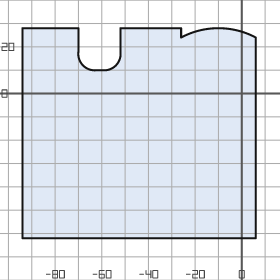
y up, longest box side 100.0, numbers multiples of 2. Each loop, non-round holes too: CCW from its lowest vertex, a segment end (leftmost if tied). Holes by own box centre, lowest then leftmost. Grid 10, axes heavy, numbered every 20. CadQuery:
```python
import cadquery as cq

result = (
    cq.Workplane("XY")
    .moveTo(-94.0, -62.0)
    .lineTo(6.0, -62.0)
    .lineTo(6.0, 24.0)
    .threePointArc((-10.0, 28.0), (-26.0, 24.0))
    .lineTo(-26.0, 28.0)
    .lineTo(-52.0, 28.0)
    .lineTo(-52.0, 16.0)
    .threePointArc((-54.0, 12.0), (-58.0, 10.0))
    .lineTo(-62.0, 10.0)
    .threePointArc((-68.0, 12.0), (-70.0, 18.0))
    .lineTo(-70.0, 28.0)
    .lineTo(-94.0, 28.0)
    .close()
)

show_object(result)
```